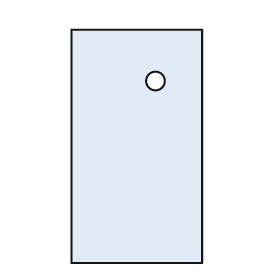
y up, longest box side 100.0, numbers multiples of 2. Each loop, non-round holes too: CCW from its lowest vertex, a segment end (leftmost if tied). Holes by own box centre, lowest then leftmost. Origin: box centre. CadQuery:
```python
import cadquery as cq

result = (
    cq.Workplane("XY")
    .moveTo(-28.0, -50.0)
    .lineTo(28.0, -50.0)
    .lineTo(28.0, 50.0)
    .lineTo(-28.0, 50.0)
    .close()
    .moveTo(8.0, 28.0)
    .circle(4.0)
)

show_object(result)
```